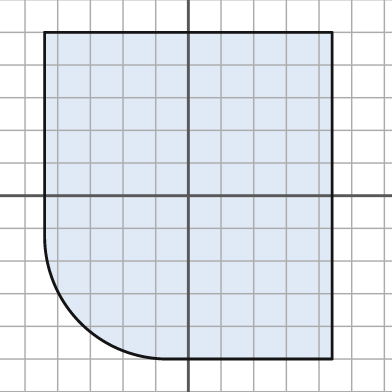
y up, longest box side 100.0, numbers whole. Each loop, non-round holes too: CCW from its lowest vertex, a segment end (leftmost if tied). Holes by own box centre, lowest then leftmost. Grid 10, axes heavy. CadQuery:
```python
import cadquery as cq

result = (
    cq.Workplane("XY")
    .moveTo(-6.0, -50.0)
    .lineTo(44.0, -50.0)
    .lineTo(44.0, 50.0)
    .lineTo(-44.0, 50.0)
    .lineTo(-44.0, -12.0)
    .threePointArc((-33.0, -39.0), (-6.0, -50.0))
    .close()
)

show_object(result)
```